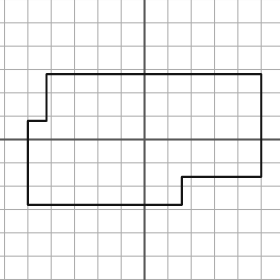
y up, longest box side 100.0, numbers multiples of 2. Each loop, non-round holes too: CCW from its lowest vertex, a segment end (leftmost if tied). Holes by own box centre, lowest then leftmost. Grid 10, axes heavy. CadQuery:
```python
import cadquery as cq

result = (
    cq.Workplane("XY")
    .moveTo(-50.0, -28.0)
    .lineTo(16.0, -28.0)
    .lineTo(16.0, -16.0)
    .lineTo(50.0, -16.0)
    .lineTo(50.0, 28.0)
    .lineTo(-42.0, 28.0)
    .lineTo(-42.0, 8.0)
    .lineTo(-50.0, 8.0)
    .close()
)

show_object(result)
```